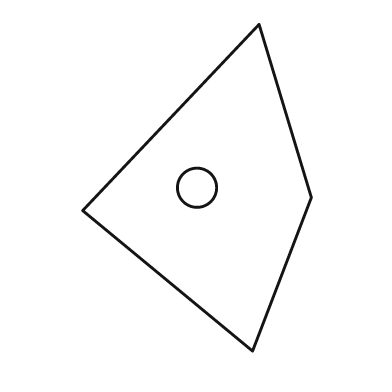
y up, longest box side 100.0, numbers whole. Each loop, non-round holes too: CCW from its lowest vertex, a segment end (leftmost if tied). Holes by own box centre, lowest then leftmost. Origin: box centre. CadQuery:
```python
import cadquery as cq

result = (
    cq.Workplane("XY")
    .moveTo(17.0, -50.0)
    .lineTo(35.0, -3.0)
    .lineTo(19.0, 50.0)
    .lineTo(-35.0, -7.0)
    .close()
    .moveTo(0.0, 0.0)
    .circle(6.0)
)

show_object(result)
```